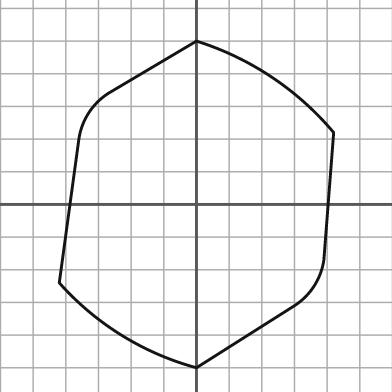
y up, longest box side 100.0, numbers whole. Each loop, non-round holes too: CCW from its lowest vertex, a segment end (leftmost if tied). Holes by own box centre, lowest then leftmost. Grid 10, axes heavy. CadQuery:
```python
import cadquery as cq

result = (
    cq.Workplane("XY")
    .moveTo(0.0, -50.0)
    .lineTo(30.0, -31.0)
    .threePointArc((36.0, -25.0), (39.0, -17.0))
    .lineTo(42.0, 22.0)
    .threePointArc((23.0, 39.0), (0.0, 50.0))
    .lineTo(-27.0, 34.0)
    .threePointArc((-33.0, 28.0), (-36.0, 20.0))
    .lineTo(-42.0, -24.0)
    .threePointArc((-23.0, -40.0), (0.0, -50.0))
    .close()
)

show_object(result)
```